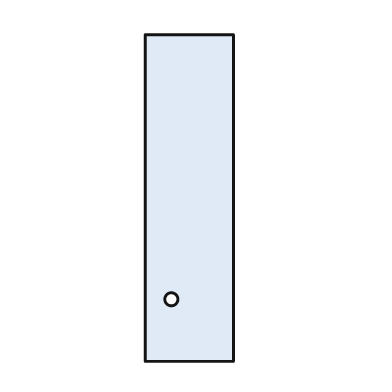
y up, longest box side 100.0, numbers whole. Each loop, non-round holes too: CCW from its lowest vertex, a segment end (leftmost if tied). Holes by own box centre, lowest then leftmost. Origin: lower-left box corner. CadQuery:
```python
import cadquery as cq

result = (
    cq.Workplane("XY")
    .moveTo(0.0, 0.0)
    .lineTo(27.0, 0.0)
    .lineTo(27.0, 100.0)
    .lineTo(0.0, 100.0)
    .close()
    .moveTo(8.0, 19.0)
    .circle(2.0)
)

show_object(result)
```